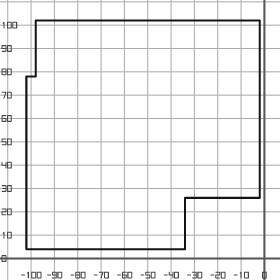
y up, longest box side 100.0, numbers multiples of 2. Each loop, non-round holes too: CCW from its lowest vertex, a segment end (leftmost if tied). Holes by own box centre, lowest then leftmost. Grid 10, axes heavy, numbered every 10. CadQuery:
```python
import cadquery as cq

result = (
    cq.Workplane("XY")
    .moveTo(-102.0, 4.0)
    .lineTo(-34.0, 4.0)
    .lineTo(-34.0, 26.0)
    .lineTo(-2.0, 26.0)
    .lineTo(-2.0, 102.0)
    .lineTo(-98.0, 102.0)
    .lineTo(-98.0, 78.0)
    .lineTo(-102.0, 78.0)
    .close()
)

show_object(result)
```